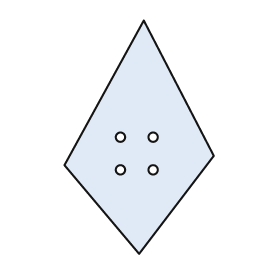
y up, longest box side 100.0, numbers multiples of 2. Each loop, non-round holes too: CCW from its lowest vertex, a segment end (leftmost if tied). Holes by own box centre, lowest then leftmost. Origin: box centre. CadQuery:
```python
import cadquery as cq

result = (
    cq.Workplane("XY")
    .moveTo(0.0, -50.0)
    .lineTo(32.0, -8.0)
    .lineTo(2.0, 50.0)
    .lineTo(-32.0, -12.0)
    .close()
    .moveTo(-8.0, -14.0)
    .circle(2.0)
    .moveTo(6.0, -14.0)
    .circle(2.0)
    .moveTo(-8.0, 0.0)
    .circle(2.0)
    .moveTo(6.0, 0.0)
    .circle(2.0)
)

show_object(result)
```